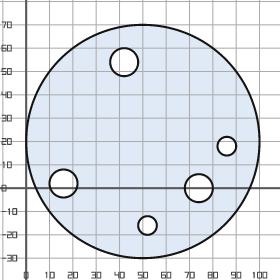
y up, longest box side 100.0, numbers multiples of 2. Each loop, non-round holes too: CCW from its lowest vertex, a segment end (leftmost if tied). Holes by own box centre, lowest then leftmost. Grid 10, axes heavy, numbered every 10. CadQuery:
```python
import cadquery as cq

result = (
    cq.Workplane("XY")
    .moveTo(50.0, 20.0)
    .circle(50.0)
    .moveTo(52.0, -16.0)
    .circle(4.0)
    .moveTo(74.0, 0.0)
    .circle(6.0)
    .moveTo(16.0, 2.0)
    .circle(6.0)
    .moveTo(86.0, 18.0)
    .circle(4.0)
    .moveTo(42.0, 54.0)
    .circle(6.0)
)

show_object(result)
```